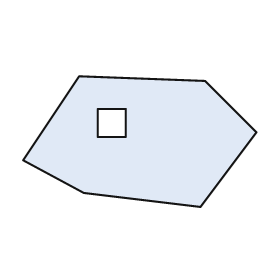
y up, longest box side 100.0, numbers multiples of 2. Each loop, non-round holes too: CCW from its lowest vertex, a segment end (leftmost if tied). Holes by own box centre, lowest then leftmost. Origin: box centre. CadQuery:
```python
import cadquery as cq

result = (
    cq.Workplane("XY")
    .moveTo(26.0, -28.0)
    .lineTo(50.0, 4.0)
    .lineTo(28.0, 26.0)
    .lineTo(-26.0, 28.0)
    .lineTo(-50.0, -8.0)
    .lineTo(-24.0, -22.0)
    .close()
    .moveTo(-18.0, 2.0)
    .lineTo(-6.0, 2.0)
    .lineTo(-6.0, 14.0)
    .lineTo(-18.0, 14.0)
    .close()
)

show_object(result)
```